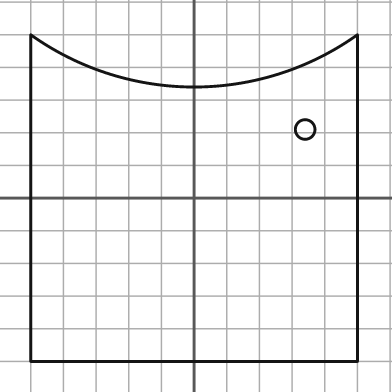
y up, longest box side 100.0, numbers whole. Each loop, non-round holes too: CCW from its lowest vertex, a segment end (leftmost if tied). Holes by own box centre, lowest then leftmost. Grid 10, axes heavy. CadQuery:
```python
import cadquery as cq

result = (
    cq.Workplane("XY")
    .moveTo(-50.0, -50.0)
    .lineTo(50.0, -50.0)
    .lineTo(50.0, 50.0)
    .threePointArc((0.0, 34.0), (-50.0, 50.0))
    .close()
    .moveTo(34.0, 21.0)
    .circle(3.0)
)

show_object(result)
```